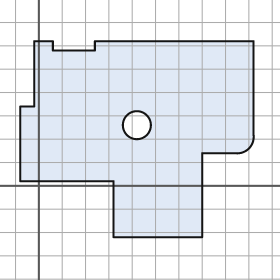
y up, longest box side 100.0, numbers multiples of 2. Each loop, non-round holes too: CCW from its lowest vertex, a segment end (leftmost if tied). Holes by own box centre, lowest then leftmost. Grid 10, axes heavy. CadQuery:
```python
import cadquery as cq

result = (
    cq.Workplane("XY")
    .moveTo(32.0, -22.0)
    .lineTo(70.0, -22.0)
    .lineTo(70.0, 14.0)
    .lineTo(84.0, 14.0)
    .threePointArc((90.0, 16.0), (92.0, 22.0))
    .lineTo(92.0, 62.0)
    .lineTo(24.0, 62.0)
    .lineTo(24.0, 58.0)
    .lineTo(6.0, 58.0)
    .lineTo(6.0, 62.0)
    .lineTo(-2.0, 62.0)
    .lineTo(-2.0, 34.0)
    .lineTo(-8.0, 34.0)
    .lineTo(-8.0, 2.0)
    .lineTo(32.0, 2.0)
    .close()
    .moveTo(42.0, 26.0)
    .circle(6.0)
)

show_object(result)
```